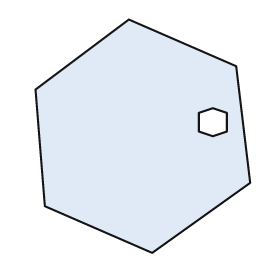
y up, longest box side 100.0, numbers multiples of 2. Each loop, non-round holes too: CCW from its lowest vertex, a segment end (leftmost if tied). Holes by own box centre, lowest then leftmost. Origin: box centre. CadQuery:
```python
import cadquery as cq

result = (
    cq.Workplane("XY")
    .moveTo(4.0, -50.0)
    .lineTo(46.0, -20.0)
    .lineTo(40.0, 30.0)
    .lineTo(-6.0, 50.0)
    .lineTo(-46.0, 20.0)
    .lineTo(-42.0, -30.0)
    .close()
    .moveTo(30.0, 0.0)
    .lineTo(36.0, 2.0)
    .lineTo(36.0, 10.0)
    .lineTo(30.0, 12.0)
    .lineTo(24.0, 10.0)
    .lineTo(24.0, 2.0)
    .close()
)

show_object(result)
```